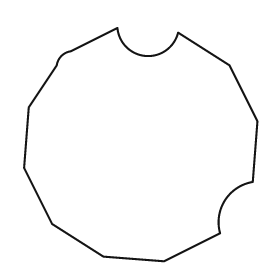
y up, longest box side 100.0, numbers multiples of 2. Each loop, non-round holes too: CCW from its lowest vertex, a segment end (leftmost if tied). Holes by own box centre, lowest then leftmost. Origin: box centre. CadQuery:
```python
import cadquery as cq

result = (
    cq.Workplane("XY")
    .moveTo(10.0, -50.0)
    .lineTo(34.0, -38.0)
    .threePointArc((36.0, -24.0), (48.0, -16.0))
    .lineTo(50.0, 10.0)
    .lineTo(38.0, 34.0)
    .lineTo(16.0, 48.0)
    .threePointArc((2.0, 38.0), (-10.0, 50.0))
    .lineTo(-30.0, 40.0)
    .threePointArc((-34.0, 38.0), (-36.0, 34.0))
    .lineTo(-48.0, 16.0)
    .lineTo(-50.0, -10.0)
    .lineTo(-38.0, -34.0)
    .lineTo(-16.0, -48.0)
    .close()
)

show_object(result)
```